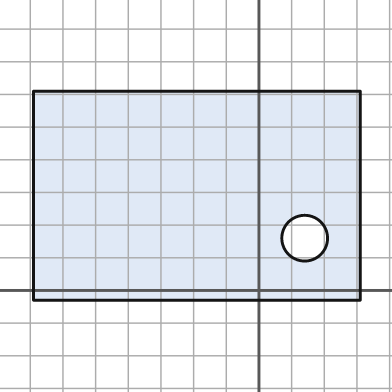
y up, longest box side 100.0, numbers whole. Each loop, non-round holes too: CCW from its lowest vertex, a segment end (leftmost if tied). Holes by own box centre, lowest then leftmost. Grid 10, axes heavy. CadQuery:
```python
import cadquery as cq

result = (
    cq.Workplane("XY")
    .moveTo(-69.0, -3.0)
    .lineTo(31.0, -3.0)
    .lineTo(31.0, 61.0)
    .lineTo(-69.0, 61.0)
    .close()
    .moveTo(14.0, 16.0)
    .circle(7.0)
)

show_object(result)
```